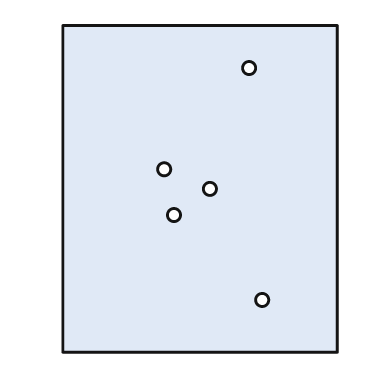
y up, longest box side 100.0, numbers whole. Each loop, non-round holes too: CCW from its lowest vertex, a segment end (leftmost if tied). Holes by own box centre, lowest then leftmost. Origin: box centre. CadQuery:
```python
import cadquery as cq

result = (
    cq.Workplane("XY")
    .moveTo(-42.0, -50.0)
    .lineTo(42.0, -50.0)
    .lineTo(42.0, 50.0)
    .lineTo(-42.0, 50.0)
    .close()
    .moveTo(19.0, -34.0)
    .circle(2.0)
    .moveTo(-8.0, -8.0)
    .circle(2.0)
    .moveTo(3.0, 0.0)
    .circle(2.0)
    .moveTo(-11.0, 6.0)
    .circle(2.0)
    .moveTo(15.0, 37.0)
    .circle(2.0)
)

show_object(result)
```